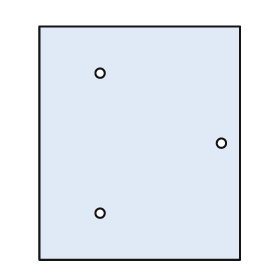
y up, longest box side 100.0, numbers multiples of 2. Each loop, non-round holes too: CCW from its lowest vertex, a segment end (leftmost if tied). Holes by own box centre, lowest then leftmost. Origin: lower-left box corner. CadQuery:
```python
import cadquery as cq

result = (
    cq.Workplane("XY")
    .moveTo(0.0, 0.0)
    .lineTo(86.0, 0.0)
    .lineTo(86.0, 100.0)
    .lineTo(0.0, 100.0)
    .close()
    .moveTo(26.0, 20.0)
    .circle(2.0)
    .moveTo(78.0, 50.0)
    .circle(2.0)
    .moveTo(26.0, 80.0)
    .circle(2.0)
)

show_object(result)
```